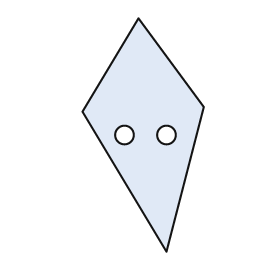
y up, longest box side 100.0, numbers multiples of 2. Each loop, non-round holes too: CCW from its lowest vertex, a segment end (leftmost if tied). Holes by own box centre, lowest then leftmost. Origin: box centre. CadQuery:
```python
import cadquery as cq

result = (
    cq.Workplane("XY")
    .moveTo(10.0, -50.0)
    .lineTo(26.0, 12.0)
    .lineTo(-2.0, 50.0)
    .lineTo(-26.0, 10.0)
    .close()
    .moveTo(-8.0, 0.0)
    .circle(4.0)
    .moveTo(10.0, 0.0)
    .circle(4.0)
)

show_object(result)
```